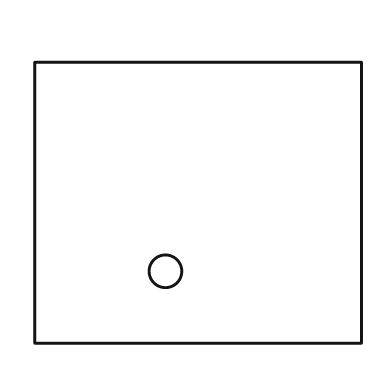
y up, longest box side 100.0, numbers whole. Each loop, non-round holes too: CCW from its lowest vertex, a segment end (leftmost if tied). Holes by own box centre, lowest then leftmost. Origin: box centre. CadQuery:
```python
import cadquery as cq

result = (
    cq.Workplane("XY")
    .moveTo(-50.0, -43.0)
    .lineTo(50.0, -43.0)
    .lineTo(50.0, 43.0)
    .lineTo(-50.0, 43.0)
    .close()
    .moveTo(-10.0, -21.0)
    .circle(5.0)
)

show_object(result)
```